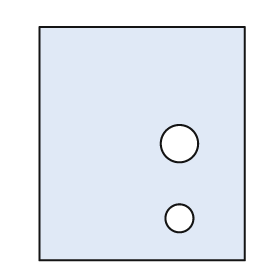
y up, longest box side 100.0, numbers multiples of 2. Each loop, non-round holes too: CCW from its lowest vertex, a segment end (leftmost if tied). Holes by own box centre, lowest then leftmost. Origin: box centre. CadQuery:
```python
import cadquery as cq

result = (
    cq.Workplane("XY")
    .moveTo(-44.0, -50.0)
    .lineTo(44.0, -50.0)
    .lineTo(44.0, 50.0)
    .lineTo(-44.0, 50.0)
    .close()
    .moveTo(16.0, -32.0)
    .circle(6.0)
    .moveTo(16.0, 0.0)
    .circle(8.0)
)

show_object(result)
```